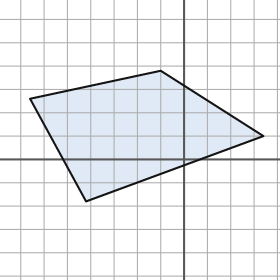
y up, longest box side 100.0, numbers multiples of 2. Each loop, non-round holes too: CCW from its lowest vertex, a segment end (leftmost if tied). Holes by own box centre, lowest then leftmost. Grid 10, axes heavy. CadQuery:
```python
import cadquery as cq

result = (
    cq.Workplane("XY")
    .moveTo(-42.0, -18.0)
    .lineTo(34.0, 10.0)
    .lineTo(-10.0, 38.0)
    .lineTo(-66.0, 26.0)
    .close()
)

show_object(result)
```